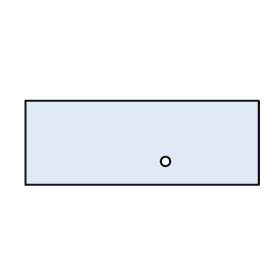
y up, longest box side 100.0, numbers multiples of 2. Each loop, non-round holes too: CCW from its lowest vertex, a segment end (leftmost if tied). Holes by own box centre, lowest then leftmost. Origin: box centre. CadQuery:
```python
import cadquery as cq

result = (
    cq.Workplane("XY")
    .moveTo(-50.0, -18.0)
    .lineTo(50.0, -18.0)
    .lineTo(50.0, 18.0)
    .lineTo(-50.0, 18.0)
    .close()
    .moveTo(10.0, -8.0)
    .circle(2.0)
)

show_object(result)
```